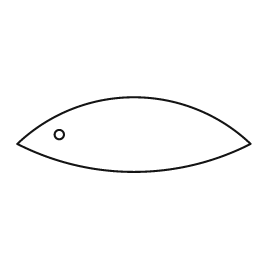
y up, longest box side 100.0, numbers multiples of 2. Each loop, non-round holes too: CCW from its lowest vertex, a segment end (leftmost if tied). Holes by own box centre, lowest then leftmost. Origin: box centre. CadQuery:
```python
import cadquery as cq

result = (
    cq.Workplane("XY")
    .moveTo(-50.0, -4.0)
    .threePointArc((0.0, -16.0), (50.0, -4.0))
    .threePointArc((0.0, 16.0), (-50.0, -4.0))
    .close()
    .moveTo(-32.0, 0.0)
    .circle(2.0)
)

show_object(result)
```